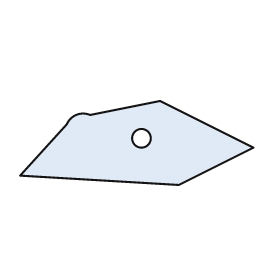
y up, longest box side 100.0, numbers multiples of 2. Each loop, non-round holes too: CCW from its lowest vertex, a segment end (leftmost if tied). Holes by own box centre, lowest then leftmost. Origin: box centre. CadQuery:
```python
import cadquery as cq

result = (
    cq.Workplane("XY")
    .moveTo(18.0, -18.0)
    .lineTo(50.0, -2.0)
    .lineTo(10.0, 18.0)
    .lineTo(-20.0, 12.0)
    .threePointArc((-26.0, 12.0), (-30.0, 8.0))
    .lineTo(-50.0, -14.0)
    .close()
    .moveTo(2.0, 2.0)
    .circle(4.0)
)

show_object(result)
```